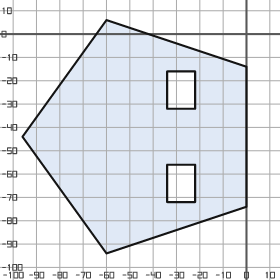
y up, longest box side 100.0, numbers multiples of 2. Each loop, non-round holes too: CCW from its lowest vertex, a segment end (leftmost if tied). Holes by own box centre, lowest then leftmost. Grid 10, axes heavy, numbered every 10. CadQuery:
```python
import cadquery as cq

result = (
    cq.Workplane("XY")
    .moveTo(-60.0, -94.0)
    .lineTo(0.0, -74.0)
    .lineTo(0.0, -14.0)
    .lineTo(-60.0, 6.0)
    .lineTo(-96.0, -44.0)
    .close()
    .moveTo(-34.0, -72.0)
    .lineTo(-22.0, -72.0)
    .lineTo(-22.0, -56.0)
    .lineTo(-34.0, -56.0)
    .close()
    .moveTo(-34.0, -32.0)
    .lineTo(-22.0, -32.0)
    .lineTo(-22.0, -16.0)
    .lineTo(-34.0, -16.0)
    .close()
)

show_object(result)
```